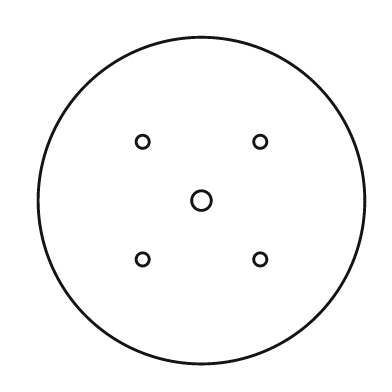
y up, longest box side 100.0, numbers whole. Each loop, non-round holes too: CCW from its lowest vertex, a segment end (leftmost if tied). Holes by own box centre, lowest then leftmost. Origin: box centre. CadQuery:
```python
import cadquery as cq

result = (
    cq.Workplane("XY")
    .moveTo(0.0, 0.0)
    .circle(50.0)
    .moveTo(-18.0, -18.0)
    .circle(2.0)
    .moveTo(18.0, -18.0)
    .circle(2.0)
    .moveTo(0.0, 0.0)
    .circle(3.0)
    .moveTo(-18.0, 18.0)
    .circle(2.0)
    .moveTo(18.0, 18.0)
    .circle(2.0)
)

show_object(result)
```